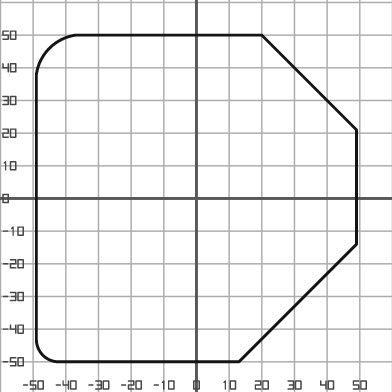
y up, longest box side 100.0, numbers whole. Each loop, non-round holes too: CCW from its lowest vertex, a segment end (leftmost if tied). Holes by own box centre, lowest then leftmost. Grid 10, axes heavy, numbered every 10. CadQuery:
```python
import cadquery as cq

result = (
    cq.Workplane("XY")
    .moveTo(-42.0, -50.0)
    .lineTo(13.0, -50.0)
    .lineTo(49.0, -14.0)
    .lineTo(49.0, 21.0)
    .lineTo(20.0, 50.0)
    .lineTo(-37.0, 50.0)
    .threePointArc((-45.0, 46.0), (-49.0, 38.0))
    .lineTo(-49.0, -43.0)
    .threePointArc((-47.0, -48.0), (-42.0, -50.0))
    .close()
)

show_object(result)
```